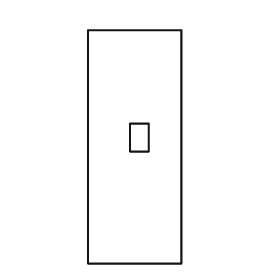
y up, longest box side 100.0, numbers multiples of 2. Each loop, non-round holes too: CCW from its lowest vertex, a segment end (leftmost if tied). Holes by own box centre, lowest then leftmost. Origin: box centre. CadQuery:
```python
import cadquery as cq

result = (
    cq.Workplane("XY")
    .moveTo(-20.0, -50.0)
    .lineTo(20.0, -50.0)
    .lineTo(20.0, 50.0)
    .lineTo(-20.0, 50.0)
    .close()
    .moveTo(-2.0, -2.0)
    .lineTo(6.0, -2.0)
    .lineTo(6.0, 10.0)
    .lineTo(-2.0, 10.0)
    .close()
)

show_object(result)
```